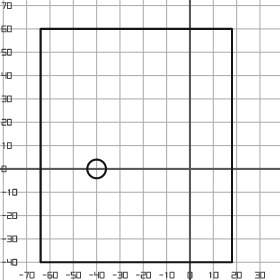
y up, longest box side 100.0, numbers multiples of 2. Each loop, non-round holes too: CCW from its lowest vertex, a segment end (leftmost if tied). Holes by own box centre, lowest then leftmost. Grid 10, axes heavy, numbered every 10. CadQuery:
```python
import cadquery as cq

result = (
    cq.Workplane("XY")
    .moveTo(-64.0, -40.0)
    .lineTo(18.0, -40.0)
    .lineTo(18.0, 60.0)
    .lineTo(-64.0, 60.0)
    .close()
    .moveTo(-40.0, 0.0)
    .circle(4.0)
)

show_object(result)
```